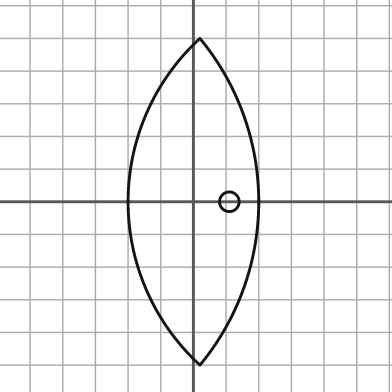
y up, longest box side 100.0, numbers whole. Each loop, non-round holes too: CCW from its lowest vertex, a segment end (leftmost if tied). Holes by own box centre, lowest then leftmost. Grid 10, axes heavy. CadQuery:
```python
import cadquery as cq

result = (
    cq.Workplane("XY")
    .moveTo(2.0, -50.0)
    .threePointArc((20.0, 0.0), (2.0, 50.0))
    .threePointArc((-20.0, 0.0), (2.0, -50.0))
    .close()
    .moveTo(11.0, 0.0)
    .circle(3.0)
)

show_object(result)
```